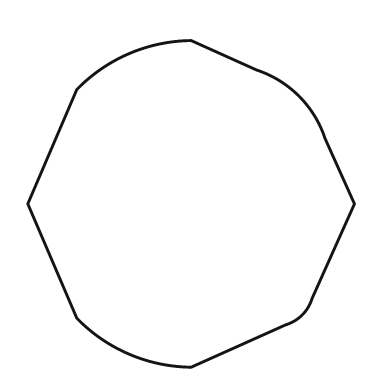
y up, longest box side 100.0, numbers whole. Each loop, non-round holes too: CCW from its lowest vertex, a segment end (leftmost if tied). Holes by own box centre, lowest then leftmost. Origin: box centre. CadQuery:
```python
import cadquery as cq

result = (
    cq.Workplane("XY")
    .moveTo(0.0, -50.0)
    .lineTo(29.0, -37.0)
    .threePointArc((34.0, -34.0), (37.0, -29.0))
    .lineTo(50.0, 0.0)
    .lineTo(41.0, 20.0)
    .threePointArc((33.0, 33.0), (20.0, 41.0))
    .lineTo(0.0, 50.0)
    .threePointArc((-19.0, 46.0), (-35.0, 35.0))
    .lineTo(-50.0, 0.0)
    .lineTo(-35.0, -35.0)
    .threePointArc((-19.0, -46.0), (0.0, -50.0))
    .close()
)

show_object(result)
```